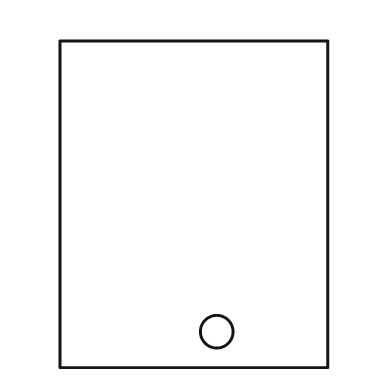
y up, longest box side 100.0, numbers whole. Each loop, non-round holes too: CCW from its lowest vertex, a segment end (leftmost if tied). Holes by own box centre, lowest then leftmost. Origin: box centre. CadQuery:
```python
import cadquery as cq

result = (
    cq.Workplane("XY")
    .moveTo(-41.0, -50.0)
    .lineTo(41.0, -50.0)
    .lineTo(41.0, 50.0)
    .lineTo(-41.0, 50.0)
    .close()
    .moveTo(7.0, -39.0)
    .circle(5.0)
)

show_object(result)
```